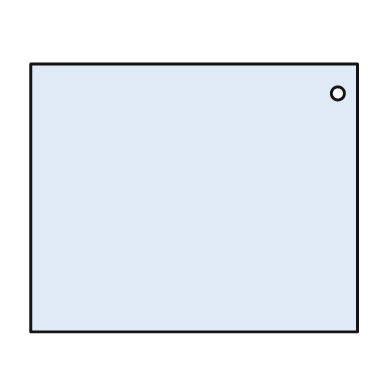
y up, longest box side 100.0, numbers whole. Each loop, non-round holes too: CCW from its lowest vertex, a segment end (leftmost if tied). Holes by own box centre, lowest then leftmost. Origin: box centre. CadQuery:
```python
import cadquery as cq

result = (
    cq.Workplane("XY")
    .moveTo(-50.0, -41.0)
    .lineTo(50.0, -41.0)
    .lineTo(50.0, 41.0)
    .lineTo(-50.0, 41.0)
    .close()
    .moveTo(44.0, 32.0)
    .circle(2.0)
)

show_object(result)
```